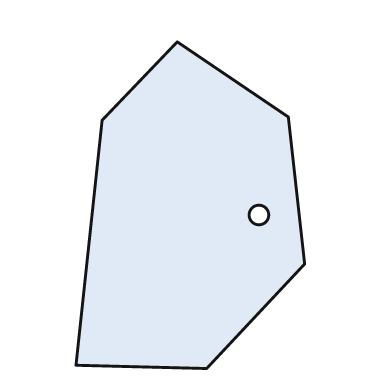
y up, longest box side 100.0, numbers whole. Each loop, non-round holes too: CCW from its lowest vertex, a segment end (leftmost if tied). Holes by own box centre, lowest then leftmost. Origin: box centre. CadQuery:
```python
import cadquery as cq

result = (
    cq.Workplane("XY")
    .moveTo(5.0, -50.0)
    .lineTo(35.0, -18.0)
    .lineTo(30.0, 27.0)
    .lineTo(-4.0, 50.0)
    .lineTo(-27.0, 26.0)
    .lineTo(-35.0, -49.0)
    .close()
    .moveTo(21.0, -3.0)
    .circle(3.0)
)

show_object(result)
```